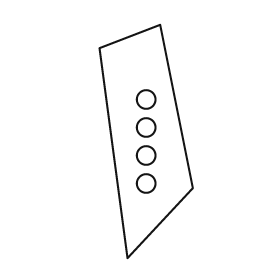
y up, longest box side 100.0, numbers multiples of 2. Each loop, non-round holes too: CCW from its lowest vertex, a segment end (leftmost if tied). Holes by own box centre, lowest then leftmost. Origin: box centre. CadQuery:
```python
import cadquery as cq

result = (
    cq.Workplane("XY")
    .moveTo(-8.0, -50.0)
    .lineTo(20.0, -20.0)
    .lineTo(6.0, 50.0)
    .lineTo(-20.0, 40.0)
    .close()
    .moveTo(0.0, -18.0)
    .circle(4.0)
    .moveTo(0.0, -6.0)
    .circle(4.0)
    .moveTo(0.0, 6.0)
    .circle(4.0)
    .moveTo(0.0, 18.0)
    .circle(4.0)
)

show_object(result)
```